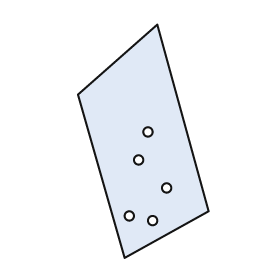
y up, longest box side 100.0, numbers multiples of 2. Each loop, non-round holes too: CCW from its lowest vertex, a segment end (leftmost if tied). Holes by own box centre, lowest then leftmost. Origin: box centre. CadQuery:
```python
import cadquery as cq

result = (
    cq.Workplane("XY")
    .moveTo(-8.0, -50.0)
    .lineTo(28.0, -30.0)
    .lineTo(6.0, 50.0)
    .lineTo(-28.0, 20.0)
    .close()
    .moveTo(4.0, -34.0)
    .circle(2.0)
    .moveTo(-6.0, -32.0)
    .circle(2.0)
    .moveTo(10.0, -20.0)
    .circle(2.0)
    .moveTo(-2.0, -8.0)
    .circle(2.0)
    .moveTo(2.0, 4.0)
    .circle(2.0)
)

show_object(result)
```